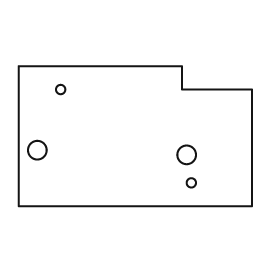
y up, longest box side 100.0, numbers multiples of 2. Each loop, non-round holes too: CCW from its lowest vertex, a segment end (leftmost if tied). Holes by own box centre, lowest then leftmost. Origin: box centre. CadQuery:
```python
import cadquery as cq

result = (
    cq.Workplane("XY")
    .moveTo(-50.0, -30.0)
    .lineTo(50.0, -30.0)
    .lineTo(50.0, 20.0)
    .lineTo(20.0, 20.0)
    .lineTo(20.0, 30.0)
    .lineTo(-50.0, 30.0)
    .close()
    .moveTo(24.0, -20.0)
    .circle(2.0)
    .moveTo(22.0, -8.0)
    .circle(4.0)
    .moveTo(-42.0, -6.0)
    .circle(4.0)
    .moveTo(-32.0, 20.0)
    .circle(2.0)
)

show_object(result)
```